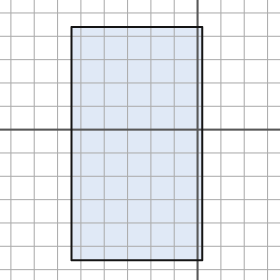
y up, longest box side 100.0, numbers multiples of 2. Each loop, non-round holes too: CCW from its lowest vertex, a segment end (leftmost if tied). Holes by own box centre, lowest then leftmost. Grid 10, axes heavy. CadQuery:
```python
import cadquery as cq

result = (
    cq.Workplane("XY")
    .moveTo(-54.0, -56.0)
    .lineTo(2.0, -56.0)
    .lineTo(2.0, 44.0)
    .lineTo(-54.0, 44.0)
    .close()
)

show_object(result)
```